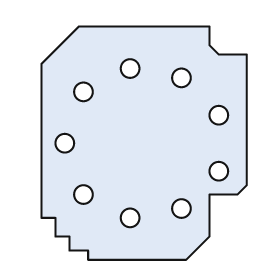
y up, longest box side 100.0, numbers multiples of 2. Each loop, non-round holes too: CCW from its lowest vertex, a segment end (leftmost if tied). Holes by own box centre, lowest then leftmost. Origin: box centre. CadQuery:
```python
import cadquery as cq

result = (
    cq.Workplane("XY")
    .moveTo(-24.0, -50.0)
    .lineTo(18.0, -50.0)
    .lineTo(28.0, -40.0)
    .lineTo(28.0, -22.0)
    .lineTo(40.0, -22.0)
    .lineTo(44.0, -18.0)
    .lineTo(44.0, 38.0)
    .lineTo(32.0, 38.0)
    .lineTo(28.0, 42.0)
    .lineTo(28.0, 50.0)
    .lineTo(-28.0, 50.0)
    .lineTo(-44.0, 34.0)
    .lineTo(-44.0, -32.0)
    .lineTo(-38.0, -32.0)
    .lineTo(-38.0, -40.0)
    .lineTo(-32.0, -40.0)
    .lineTo(-32.0, -46.0)
    .lineTo(-24.0, -46.0)
    .close()
    .moveTo(-6.0, -32.0)
    .circle(4.0)
    .moveTo(16.0, -28.0)
    .circle(4.0)
    .moveTo(-26.0, -22.0)
    .circle(4.0)
    .moveTo(32.0, -12.0)
    .circle(4.0)
    .moveTo(-34.0, 0.0)
    .circle(4.0)
    .moveTo(32.0, 12.0)
    .circle(4.0)
    .moveTo(-26.0, 22.0)
    .circle(4.0)
    .moveTo(16.0, 28.0)
    .circle(4.0)
    .moveTo(-6.0, 32.0)
    .circle(4.0)
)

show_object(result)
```